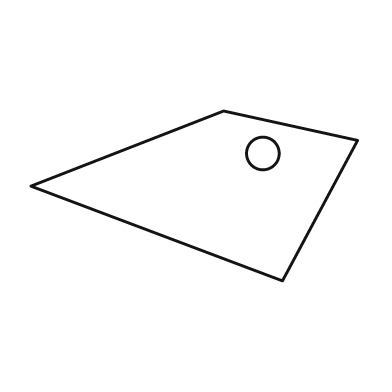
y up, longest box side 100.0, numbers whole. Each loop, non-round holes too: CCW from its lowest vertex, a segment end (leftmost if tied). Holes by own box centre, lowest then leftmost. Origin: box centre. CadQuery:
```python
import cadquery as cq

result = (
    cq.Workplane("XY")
    .moveTo(27.0, -26.0)
    .lineTo(50.0, 17.0)
    .lineTo(9.0, 26.0)
    .lineTo(-50.0, 3.0)
    .close()
    .moveTo(21.0, 13.0)
    .circle(5.0)
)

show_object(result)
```